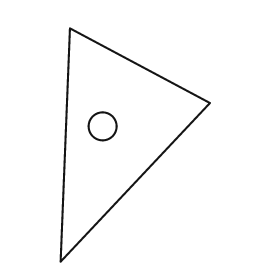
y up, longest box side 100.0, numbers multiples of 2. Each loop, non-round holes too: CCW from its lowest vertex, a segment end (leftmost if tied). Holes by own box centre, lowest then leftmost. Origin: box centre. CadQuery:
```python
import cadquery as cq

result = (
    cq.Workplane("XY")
    .moveTo(-32.0, -50.0)
    .lineTo(32.0, 18.0)
    .lineTo(-28.0, 50.0)
    .close()
    .moveTo(-14.0, 8.0)
    .circle(6.0)
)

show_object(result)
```